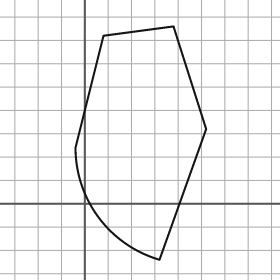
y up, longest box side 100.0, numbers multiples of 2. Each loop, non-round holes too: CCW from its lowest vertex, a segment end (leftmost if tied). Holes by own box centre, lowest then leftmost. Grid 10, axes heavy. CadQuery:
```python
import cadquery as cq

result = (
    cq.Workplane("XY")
    .moveTo(32.0, -24.0)
    .lineTo(52.0, 32.0)
    .lineTo(38.0, 76.0)
    .lineTo(8.0, 72.0)
    .lineTo(-4.0, 24.0)
    .threePointArc((6.0, -6.0), (32.0, -24.0))
    .close()
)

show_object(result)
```